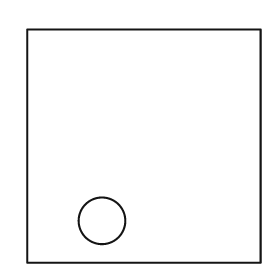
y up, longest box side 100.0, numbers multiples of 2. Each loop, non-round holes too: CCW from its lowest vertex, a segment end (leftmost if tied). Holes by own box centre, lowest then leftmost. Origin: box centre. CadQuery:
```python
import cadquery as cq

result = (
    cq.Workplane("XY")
    .moveTo(-50.0, -50.0)
    .lineTo(50.0, -50.0)
    .lineTo(50.0, 50.0)
    .lineTo(-50.0, 50.0)
    .close()
    .moveTo(-18.0, -32.0)
    .circle(10.0)
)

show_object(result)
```